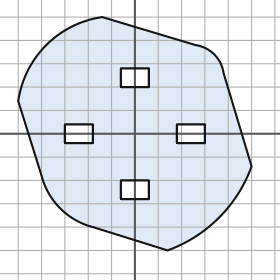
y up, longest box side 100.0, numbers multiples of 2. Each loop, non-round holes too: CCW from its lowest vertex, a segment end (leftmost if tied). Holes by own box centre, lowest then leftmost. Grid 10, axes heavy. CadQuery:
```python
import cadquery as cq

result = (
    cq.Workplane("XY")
    .moveTo(14.0, -50.0)
    .threePointArc((36.0, -36.0), (50.0, -14.0))
    .lineTo(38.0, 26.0)
    .threePointArc((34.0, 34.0), (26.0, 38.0))
    .lineTo(-14.0, 50.0)
    .threePointArc((-38.0, 38.0), (-50.0, 14.0))
    .lineTo(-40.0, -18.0)
    .threePointArc((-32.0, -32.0), (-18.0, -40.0))
    .close()
    .moveTo(-6.0, -28.0)
    .lineTo(6.0, -28.0)
    .lineTo(6.0, -20.0)
    .lineTo(-6.0, -20.0)
    .close()
    .moveTo(-30.0, -4.0)
    .lineTo(-18.0, -4.0)
    .lineTo(-18.0, 4.0)
    .lineTo(-30.0, 4.0)
    .close()
    .moveTo(18.0, -4.0)
    .lineTo(30.0, -4.0)
    .lineTo(30.0, 4.0)
    .lineTo(18.0, 4.0)
    .close()
    .moveTo(-6.0, 20.0)
    .lineTo(6.0, 20.0)
    .lineTo(6.0, 28.0)
    .lineTo(-6.0, 28.0)
    .close()
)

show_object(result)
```